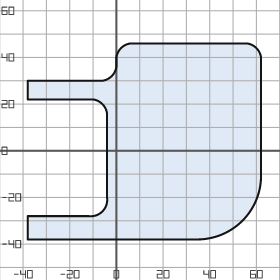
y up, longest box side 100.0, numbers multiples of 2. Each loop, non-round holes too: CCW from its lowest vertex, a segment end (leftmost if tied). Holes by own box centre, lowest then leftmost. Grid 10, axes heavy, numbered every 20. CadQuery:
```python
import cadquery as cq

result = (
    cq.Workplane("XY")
    .moveTo(-38.0, -38.0)
    .lineTo(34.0, -38.0)
    .threePointArc((54.0, -30.0), (62.0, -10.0))
    .lineTo(62.0, 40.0)
    .threePointArc((60.0, 44.0), (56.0, 46.0))
    .lineTo(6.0, 46.0)
    .threePointArc((2.0, 44.0), (0.0, 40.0))
    .lineTo(0.0, 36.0)
    .threePointArc((-2.0, 32.0), (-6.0, 30.0))
    .lineTo(-38.0, 30.0)
    .lineTo(-38.0, 22.0)
    .lineTo(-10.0, 22.0)
    .threePointArc((-6.0, 20.0), (-4.0, 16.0))
    .lineTo(-4.0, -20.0)
    .threePointArc((-6.0, -26.0), (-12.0, -28.0))
    .lineTo(-38.0, -28.0)
    .close()
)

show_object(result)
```